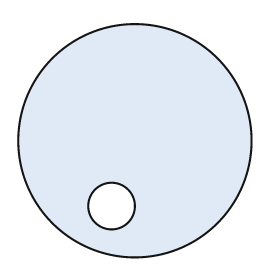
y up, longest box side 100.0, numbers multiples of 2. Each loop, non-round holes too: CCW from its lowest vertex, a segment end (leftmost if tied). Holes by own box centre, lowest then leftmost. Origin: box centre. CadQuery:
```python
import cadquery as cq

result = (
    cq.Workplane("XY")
    .moveTo(0.0, 0.0)
    .circle(50.0)
    .moveTo(-10.0, -28.0)
    .circle(10.0)
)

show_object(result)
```